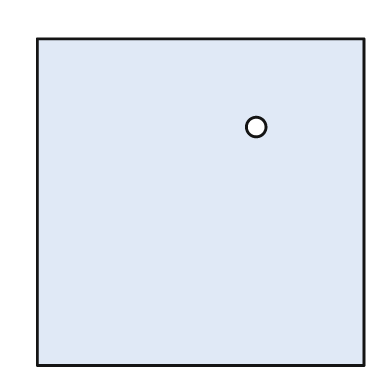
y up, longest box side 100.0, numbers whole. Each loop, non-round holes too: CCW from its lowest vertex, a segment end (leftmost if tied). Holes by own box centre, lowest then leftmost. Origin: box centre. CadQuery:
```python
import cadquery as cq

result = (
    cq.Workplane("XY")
    .moveTo(-50.0, -50.0)
    .lineTo(50.0, -50.0)
    .lineTo(50.0, 50.0)
    .lineTo(-50.0, 50.0)
    .close()
    .moveTo(17.0, 23.0)
    .circle(3.0)
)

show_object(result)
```